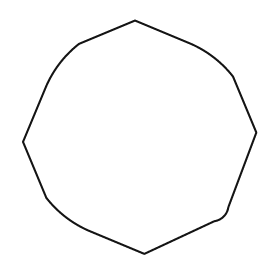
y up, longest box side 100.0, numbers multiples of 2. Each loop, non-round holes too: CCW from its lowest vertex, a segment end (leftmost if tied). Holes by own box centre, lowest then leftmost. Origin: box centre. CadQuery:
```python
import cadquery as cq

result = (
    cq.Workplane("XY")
    .moveTo(2.0, -50.0)
    .lineTo(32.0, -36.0)
    .threePointArc((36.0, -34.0), (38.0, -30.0))
    .lineTo(50.0, 2.0)
    .lineTo(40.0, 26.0)
    .threePointArc((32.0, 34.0), (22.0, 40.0))
    .lineTo(-2.0, 50.0)
    .lineTo(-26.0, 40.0)
    .threePointArc((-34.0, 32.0), (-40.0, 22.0))
    .lineTo(-50.0, -2.0)
    .lineTo(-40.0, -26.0)
    .threePointArc((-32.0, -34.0), (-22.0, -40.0))
    .close()
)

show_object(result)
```